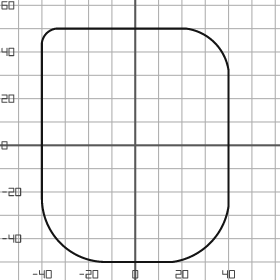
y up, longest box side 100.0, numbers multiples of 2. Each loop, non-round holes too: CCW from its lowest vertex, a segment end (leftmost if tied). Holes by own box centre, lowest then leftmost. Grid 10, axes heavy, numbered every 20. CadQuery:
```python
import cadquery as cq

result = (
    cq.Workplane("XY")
    .moveTo(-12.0, -50.0)
    .lineTo(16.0, -50.0)
    .threePointArc((32.0, -42.0), (40.0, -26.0))
    .lineTo(40.0, 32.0)
    .threePointArc((34.0, 44.0), (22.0, 50.0))
    .lineTo(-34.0, 50.0)
    .threePointArc((-38.0, 48.0), (-40.0, 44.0))
    .lineTo(-40.0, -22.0)
    .threePointArc((-32.0, -42.0), (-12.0, -50.0))
    .close()
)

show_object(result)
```